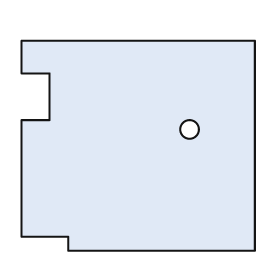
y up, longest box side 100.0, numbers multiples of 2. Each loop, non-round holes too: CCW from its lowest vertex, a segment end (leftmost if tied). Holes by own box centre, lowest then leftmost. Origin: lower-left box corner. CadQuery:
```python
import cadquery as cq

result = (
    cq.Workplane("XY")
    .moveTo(20.0, 0.0)
    .lineTo(100.0, 0.0)
    .lineTo(100.0, 90.0)
    .lineTo(0.0, 90.0)
    .lineTo(0.0, 76.0)
    .lineTo(12.0, 76.0)
    .lineTo(12.0, 56.0)
    .lineTo(0.0, 56.0)
    .lineTo(0.0, 6.0)
    .lineTo(20.0, 6.0)
    .close()
    .moveTo(72.0, 52.0)
    .circle(4.0)
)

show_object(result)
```